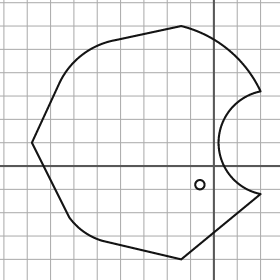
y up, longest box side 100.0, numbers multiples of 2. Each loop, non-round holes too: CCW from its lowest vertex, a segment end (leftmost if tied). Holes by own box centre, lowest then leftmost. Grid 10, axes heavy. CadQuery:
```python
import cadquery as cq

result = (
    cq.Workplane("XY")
    .moveTo(-14.0, -40.0)
    .lineTo(20.0, -12.0)
    .threePointArc((2.0, 10.0), (20.0, 32.0))
    .threePointArc((6.0, 50.0), (-14.0, 60.0))
    .lineTo(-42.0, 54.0)
    .threePointArc((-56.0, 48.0), (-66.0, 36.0))
    .lineTo(-78.0, 10.0)
    .lineTo(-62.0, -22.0)
    .threePointArc((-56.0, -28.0), (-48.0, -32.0))
    .close()
    .moveTo(-6.0, -8.0)
    .circle(2.0)
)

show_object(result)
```